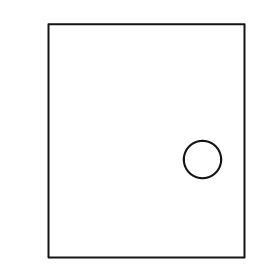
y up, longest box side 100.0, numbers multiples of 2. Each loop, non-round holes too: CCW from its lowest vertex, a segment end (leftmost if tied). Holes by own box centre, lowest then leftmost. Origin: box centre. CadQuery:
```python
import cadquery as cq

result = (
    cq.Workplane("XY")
    .moveTo(-42.0, -50.0)
    .lineTo(42.0, -50.0)
    .lineTo(42.0, 50.0)
    .lineTo(-42.0, 50.0)
    .close()
    .moveTo(24.0, -8.0)
    .circle(8.0)
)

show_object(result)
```